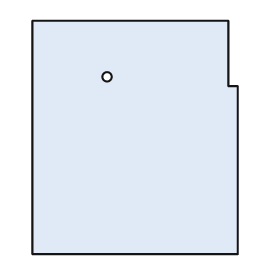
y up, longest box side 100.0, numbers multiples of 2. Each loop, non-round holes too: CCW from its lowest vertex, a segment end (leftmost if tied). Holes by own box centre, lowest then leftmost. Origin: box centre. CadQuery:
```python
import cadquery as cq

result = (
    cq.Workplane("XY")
    .moveTo(-44.0, -50.0)
    .lineTo(44.0, -50.0)
    .lineTo(44.0, 22.0)
    .lineTo(40.0, 22.0)
    .lineTo(40.0, 50.0)
    .lineTo(-44.0, 50.0)
    .close()
    .moveTo(-12.0, 26.0)
    .circle(2.0)
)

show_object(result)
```